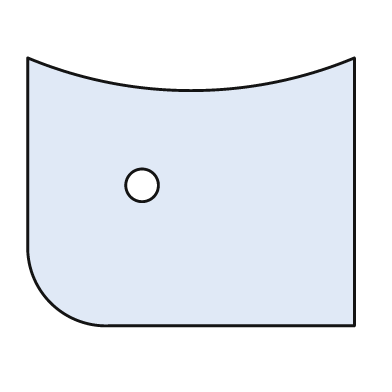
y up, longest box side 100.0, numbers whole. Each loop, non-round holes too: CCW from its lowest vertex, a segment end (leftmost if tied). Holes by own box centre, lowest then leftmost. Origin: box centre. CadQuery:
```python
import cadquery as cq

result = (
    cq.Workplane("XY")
    .moveTo(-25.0, -41.0)
    .lineTo(50.0, -41.0)
    .lineTo(50.0, 41.0)
    .threePointArc((0.0, 31.0), (-50.0, 41.0))
    .lineTo(-50.0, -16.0)
    .threePointArc((-43.0, -34.0), (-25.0, -41.0))
    .close()
    .moveTo(-15.0, 2.0)
    .circle(5.0)
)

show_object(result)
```